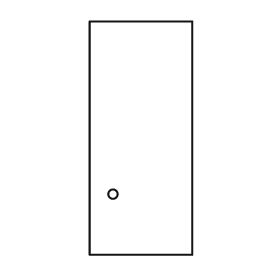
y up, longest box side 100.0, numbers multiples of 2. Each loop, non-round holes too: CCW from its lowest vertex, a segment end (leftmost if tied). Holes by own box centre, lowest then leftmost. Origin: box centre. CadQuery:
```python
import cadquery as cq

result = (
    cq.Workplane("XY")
    .moveTo(-22.0, -50.0)
    .lineTo(22.0, -50.0)
    .lineTo(22.0, 50.0)
    .lineTo(-22.0, 50.0)
    .close()
    .moveTo(-12.0, -24.0)
    .circle(2.0)
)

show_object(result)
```